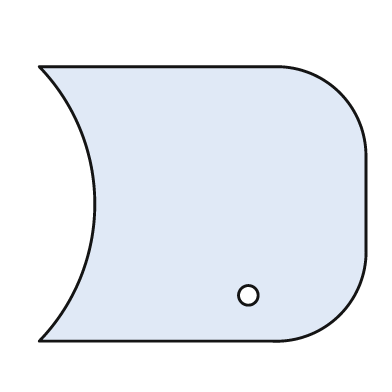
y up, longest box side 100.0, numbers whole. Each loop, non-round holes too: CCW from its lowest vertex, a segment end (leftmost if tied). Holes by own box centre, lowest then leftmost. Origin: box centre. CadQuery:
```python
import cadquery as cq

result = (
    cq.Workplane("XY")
    .moveTo(-50.0, -42.0)
    .lineTo(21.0, -42.0)
    .threePointArc((42.0, -34.0), (50.0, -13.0))
    .lineTo(50.0, 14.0)
    .threePointArc((42.0, 34.0), (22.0, 42.0))
    .lineTo(-50.0, 42.0)
    .threePointArc((-33.0, 0.0), (-50.0, -42.0))
    .close()
    .moveTo(14.0, -28.0)
    .circle(3.0)
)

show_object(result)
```